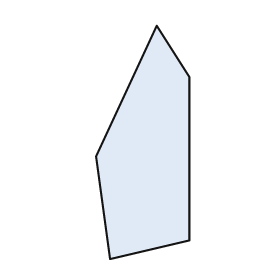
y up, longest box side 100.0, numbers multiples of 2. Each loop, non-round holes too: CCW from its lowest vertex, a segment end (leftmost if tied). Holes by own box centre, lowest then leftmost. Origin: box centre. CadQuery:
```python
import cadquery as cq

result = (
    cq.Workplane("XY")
    .moveTo(-14.0, -50.0)
    .lineTo(20.0, -42.0)
    .lineTo(20.0, 28.0)
    .lineTo(6.0, 50.0)
    .lineTo(-20.0, -6.0)
    .close()
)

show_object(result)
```